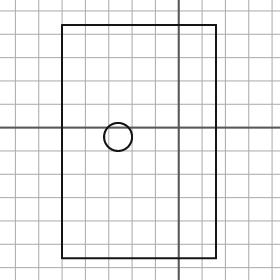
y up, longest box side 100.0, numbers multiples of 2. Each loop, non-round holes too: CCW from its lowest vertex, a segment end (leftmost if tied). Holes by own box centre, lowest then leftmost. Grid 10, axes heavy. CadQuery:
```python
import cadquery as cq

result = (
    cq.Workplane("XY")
    .moveTo(-50.0, -56.0)
    .lineTo(16.0, -56.0)
    .lineTo(16.0, 44.0)
    .lineTo(-50.0, 44.0)
    .close()
    .moveTo(-26.0, -4.0)
    .circle(6.0)
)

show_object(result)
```